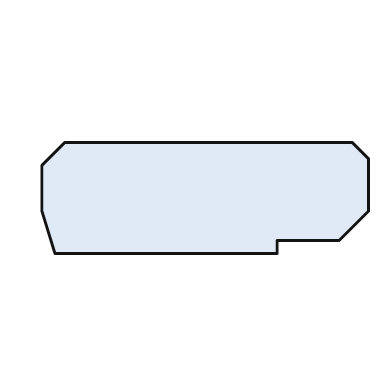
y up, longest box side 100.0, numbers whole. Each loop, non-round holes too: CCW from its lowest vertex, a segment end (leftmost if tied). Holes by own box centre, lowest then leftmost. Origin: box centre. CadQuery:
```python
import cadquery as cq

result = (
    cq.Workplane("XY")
    .moveTo(-46.0, -17.0)
    .lineTo(22.0, -17.0)
    .lineTo(22.0, -13.0)
    .lineTo(41.0, -13.0)
    .lineTo(50.0, -4.0)
    .lineTo(50.0, 12.0)
    .lineTo(45.0, 17.0)
    .lineTo(-43.0, 17.0)
    .lineTo(-50.0, 10.0)
    .lineTo(-50.0, -4.0)
    .close()
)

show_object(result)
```